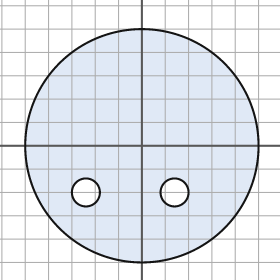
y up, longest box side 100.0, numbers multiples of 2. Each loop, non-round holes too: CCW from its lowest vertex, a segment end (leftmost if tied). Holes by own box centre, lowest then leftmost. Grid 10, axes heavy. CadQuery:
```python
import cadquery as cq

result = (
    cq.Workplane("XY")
    .moveTo(0.0, 0.0)
    .circle(50.0)
    .moveTo(-24.0, -20.0)
    .circle(6.0)
    .moveTo(14.0, -20.0)
    .circle(6.0)
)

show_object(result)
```